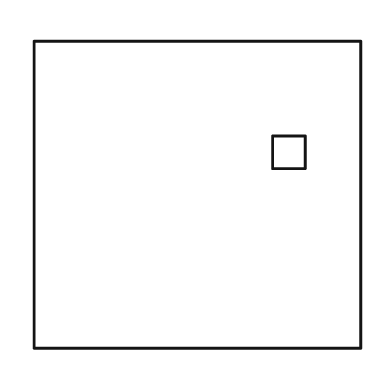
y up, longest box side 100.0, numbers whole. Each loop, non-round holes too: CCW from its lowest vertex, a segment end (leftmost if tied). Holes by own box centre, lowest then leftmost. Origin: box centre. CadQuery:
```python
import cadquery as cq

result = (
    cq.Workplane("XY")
    .moveTo(-50.0, -47.0)
    .lineTo(50.0, -47.0)
    .lineTo(50.0, 47.0)
    .lineTo(-50.0, 47.0)
    .close()
    .moveTo(23.0, 8.0)
    .lineTo(33.0, 8.0)
    .lineTo(33.0, 18.0)
    .lineTo(23.0, 18.0)
    .close()
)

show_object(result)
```